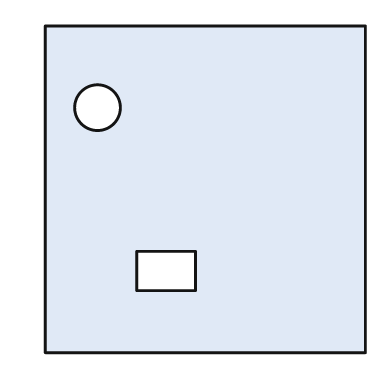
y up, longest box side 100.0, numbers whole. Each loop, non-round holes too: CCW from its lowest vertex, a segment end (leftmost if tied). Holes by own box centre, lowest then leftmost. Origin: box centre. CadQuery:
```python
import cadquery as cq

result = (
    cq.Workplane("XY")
    .moveTo(-49.0, -50.0)
    .lineTo(49.0, -50.0)
    .lineTo(49.0, 50.0)
    .lineTo(-49.0, 50.0)
    .close()
    .moveTo(-21.0, -31.0)
    .lineTo(-3.0, -31.0)
    .lineTo(-3.0, -19.0)
    .lineTo(-21.0, -19.0)
    .close()
    .moveTo(-33.0, 25.0)
    .circle(7.0)
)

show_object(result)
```